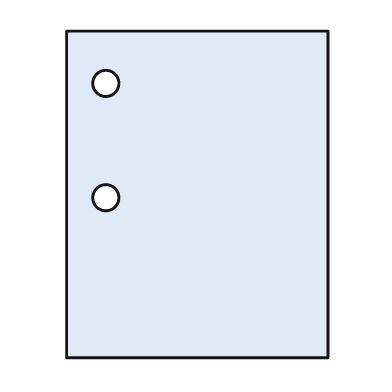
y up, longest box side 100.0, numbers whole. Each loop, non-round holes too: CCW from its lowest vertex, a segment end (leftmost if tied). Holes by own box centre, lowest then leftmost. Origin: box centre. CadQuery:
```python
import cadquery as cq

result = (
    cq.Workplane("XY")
    .moveTo(-40.0, -50.0)
    .lineTo(40.0, -50.0)
    .lineTo(40.0, 50.0)
    .lineTo(-40.0, 50.0)
    .close()
    .moveTo(-28.0, -1.0)
    .circle(4.0)
    .moveTo(-28.0, 34.0)
    .circle(4.0)
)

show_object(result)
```